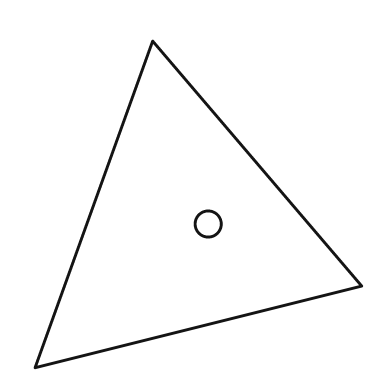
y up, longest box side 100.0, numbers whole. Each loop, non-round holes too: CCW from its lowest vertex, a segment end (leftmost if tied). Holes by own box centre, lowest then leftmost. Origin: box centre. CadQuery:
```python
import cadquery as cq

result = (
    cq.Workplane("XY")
    .moveTo(-50.0, -50.0)
    .lineTo(50.0, -25.0)
    .lineTo(-14.0, 50.0)
    .close()
    .moveTo(3.0, -6.0)
    .circle(4.0)
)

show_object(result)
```